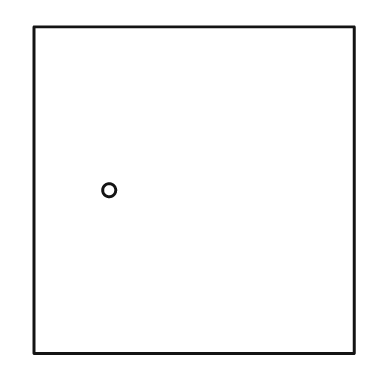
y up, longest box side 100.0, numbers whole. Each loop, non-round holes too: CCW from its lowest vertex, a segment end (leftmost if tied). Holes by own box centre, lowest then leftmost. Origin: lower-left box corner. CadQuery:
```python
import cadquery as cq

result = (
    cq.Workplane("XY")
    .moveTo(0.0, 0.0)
    .lineTo(98.0, 0.0)
    .lineTo(98.0, 100.0)
    .lineTo(0.0, 100.0)
    .close()
    .moveTo(23.0, 50.0)
    .circle(2.0)
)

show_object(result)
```